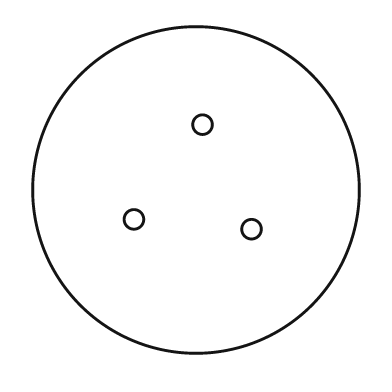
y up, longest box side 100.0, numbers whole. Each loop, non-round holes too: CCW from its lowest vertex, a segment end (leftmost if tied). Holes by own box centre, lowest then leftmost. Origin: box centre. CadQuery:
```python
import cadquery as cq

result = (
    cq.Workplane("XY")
    .moveTo(0.0, 0.0)
    .circle(50.0)
    .moveTo(17.0, -12.0)
    .circle(3.0)
    .moveTo(-19.0, -9.0)
    .circle(3.0)
    .moveTo(2.0, 20.0)
    .circle(3.0)
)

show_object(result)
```